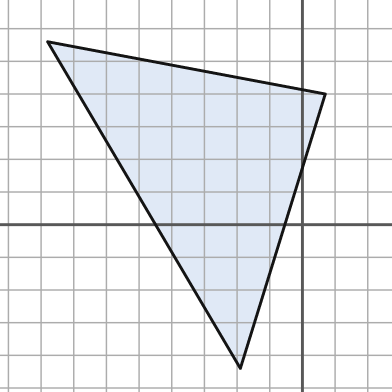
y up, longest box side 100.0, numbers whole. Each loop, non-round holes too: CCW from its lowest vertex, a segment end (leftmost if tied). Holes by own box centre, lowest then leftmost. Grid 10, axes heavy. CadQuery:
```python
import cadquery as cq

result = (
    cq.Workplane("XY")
    .moveTo(-19.0, -44.0)
    .lineTo(7.0, 40.0)
    .lineTo(-78.0, 56.0)
    .close()
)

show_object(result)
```